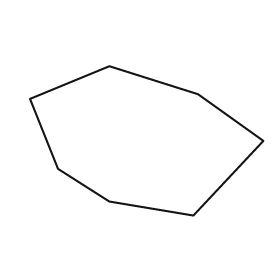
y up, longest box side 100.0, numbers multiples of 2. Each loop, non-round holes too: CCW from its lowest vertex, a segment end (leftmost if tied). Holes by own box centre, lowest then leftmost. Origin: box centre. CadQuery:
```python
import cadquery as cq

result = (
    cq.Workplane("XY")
    .moveTo(20.0, -32.0)
    .lineTo(50.0, 0.0)
    .lineTo(22.0, 20.0)
    .lineTo(-16.0, 32.0)
    .lineTo(-50.0, 18.0)
    .lineTo(-38.0, -12.0)
    .lineTo(-16.0, -26.0)
    .close()
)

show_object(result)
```